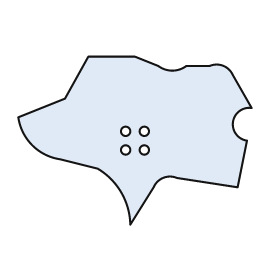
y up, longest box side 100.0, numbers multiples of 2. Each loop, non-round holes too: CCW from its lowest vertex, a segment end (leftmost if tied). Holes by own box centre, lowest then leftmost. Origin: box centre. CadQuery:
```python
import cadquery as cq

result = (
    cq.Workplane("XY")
    .moveTo(-2.0, -36.0)
    .lineTo(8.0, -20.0)
    .threePointArc((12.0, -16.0), (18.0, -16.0))
    .lineTo(44.0, -20.0)
    .lineTo(48.0, 0.0)
    .threePointArc((42.0, 8.0), (50.0, 14.0))
    .lineTo(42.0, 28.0)
    .threePointArc((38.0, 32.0), (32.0, 32.0))
    .lineTo(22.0, 32.0)
    .threePointArc((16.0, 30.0), (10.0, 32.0))
    .lineTo(0.0, 36.0)
    .lineTo(-20.0, 36.0)
    .lineTo(-30.0, 18.0)
    .lineTo(-50.0, 10.0)
    .threePointArc((-44.0, -2.0), (-32.0, -8.0))
    .lineTo(-16.0, -12.0)
    .threePointArc((-6.0, -22.0), (-2.0, -36.0))
    .close()
    .moveTo(-4.0, -4.0)
    .circle(2.0)
    .moveTo(4.0, -4.0)
    .circle(2.0)
    .moveTo(-4.0, 4.0)
    .circle(2.0)
    .moveTo(4.0, 4.0)
    .circle(2.0)
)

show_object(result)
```